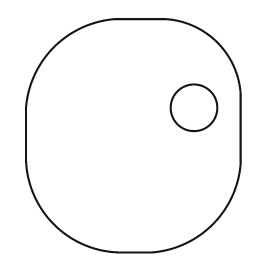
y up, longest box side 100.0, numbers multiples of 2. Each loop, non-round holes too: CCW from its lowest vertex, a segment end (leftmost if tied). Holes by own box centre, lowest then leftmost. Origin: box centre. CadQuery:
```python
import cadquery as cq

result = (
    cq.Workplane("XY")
    .moveTo(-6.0, -50.0)
    .lineTo(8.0, -50.0)
    .threePointArc((34.0, -38.0), (46.0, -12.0))
    .lineTo(46.0, 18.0)
    .threePointArc((36.0, 40.0), (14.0, 50.0))
    .lineTo(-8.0, 50.0)
    .threePointArc((-34.0, 38.0), (-46.0, 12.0))
    .lineTo(-46.0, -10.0)
    .threePointArc((-34.0, -38.0), (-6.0, -50.0))
    .close()
    .moveTo(26.0, 12.0)
    .circle(10.0)
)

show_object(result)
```